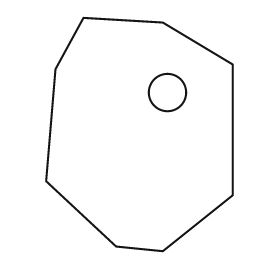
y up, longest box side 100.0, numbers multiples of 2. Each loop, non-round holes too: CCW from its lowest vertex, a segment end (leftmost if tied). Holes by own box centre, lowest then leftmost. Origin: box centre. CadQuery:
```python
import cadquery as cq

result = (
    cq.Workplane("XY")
    .moveTo(10.0, -50.0)
    .lineTo(40.0, -26.0)
    .lineTo(40.0, 30.0)
    .lineTo(10.0, 48.0)
    .lineTo(-24.0, 50.0)
    .lineTo(-36.0, 28.0)
    .lineTo(-40.0, -20.0)
    .lineTo(-10.0, -48.0)
    .close()
    .moveTo(12.0, 18.0)
    .circle(8.0)
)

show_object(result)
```